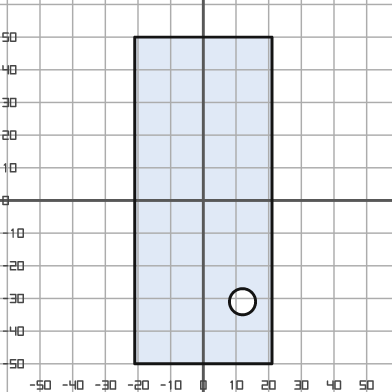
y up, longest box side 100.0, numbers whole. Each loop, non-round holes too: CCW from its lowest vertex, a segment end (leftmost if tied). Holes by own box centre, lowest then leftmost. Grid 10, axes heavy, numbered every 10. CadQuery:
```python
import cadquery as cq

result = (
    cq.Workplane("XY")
    .moveTo(-21.0, -50.0)
    .lineTo(21.0, -50.0)
    .lineTo(21.0, 50.0)
    .lineTo(-21.0, 50.0)
    .close()
    .moveTo(12.0, -31.0)
    .circle(4.0)
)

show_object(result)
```